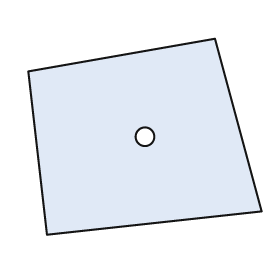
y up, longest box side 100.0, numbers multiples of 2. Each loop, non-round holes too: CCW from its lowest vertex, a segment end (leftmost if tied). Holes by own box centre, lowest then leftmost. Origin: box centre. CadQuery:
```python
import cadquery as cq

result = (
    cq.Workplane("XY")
    .moveTo(-42.0, -42.0)
    .lineTo(50.0, -32.0)
    .lineTo(30.0, 42.0)
    .lineTo(-50.0, 28.0)
    .close()
    .moveTo(0.0, 0.0)
    .circle(4.0)
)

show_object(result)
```